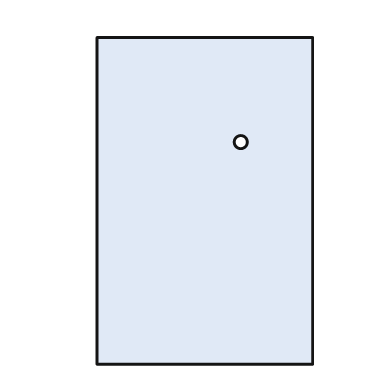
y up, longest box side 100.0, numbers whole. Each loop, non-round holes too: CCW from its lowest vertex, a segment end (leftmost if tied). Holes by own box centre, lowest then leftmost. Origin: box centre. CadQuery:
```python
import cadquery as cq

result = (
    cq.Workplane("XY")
    .moveTo(-33.0, -50.0)
    .lineTo(33.0, -50.0)
    .lineTo(33.0, 50.0)
    .lineTo(-33.0, 50.0)
    .close()
    .moveTo(11.0, 18.0)
    .circle(2.0)
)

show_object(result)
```